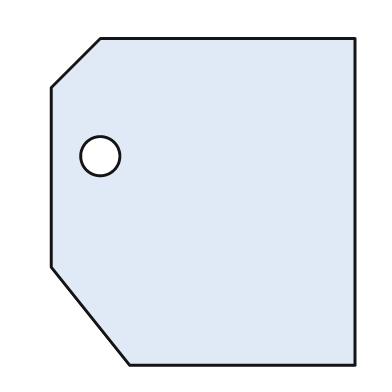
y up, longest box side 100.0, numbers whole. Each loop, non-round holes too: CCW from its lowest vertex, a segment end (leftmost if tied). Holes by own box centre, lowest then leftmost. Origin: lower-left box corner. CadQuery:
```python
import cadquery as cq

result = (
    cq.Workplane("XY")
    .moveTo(24.0, 0.0)
    .lineTo(93.0, 0.0)
    .lineTo(93.0, 100.0)
    .lineTo(15.0, 100.0)
    .lineTo(0.0, 85.0)
    .lineTo(0.0, 30.0)
    .close()
    .moveTo(15.0, 64.0)
    .circle(6.0)
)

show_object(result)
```